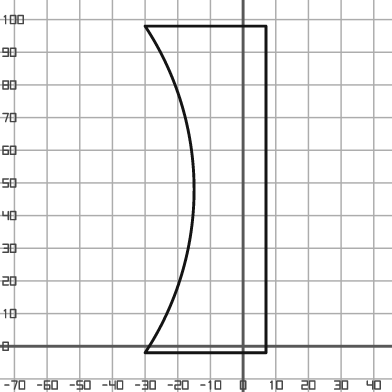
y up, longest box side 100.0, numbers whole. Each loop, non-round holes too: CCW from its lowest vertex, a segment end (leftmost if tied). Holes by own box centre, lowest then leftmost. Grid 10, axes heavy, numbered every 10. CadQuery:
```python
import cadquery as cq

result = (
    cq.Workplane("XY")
    .moveTo(-30.0, -2.0)
    .lineTo(7.0, -2.0)
    .lineTo(7.0, 98.0)
    .lineTo(-30.0, 98.0)
    .threePointArc((-15.0, 48.0), (-30.0, -2.0))
    .close()
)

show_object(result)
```